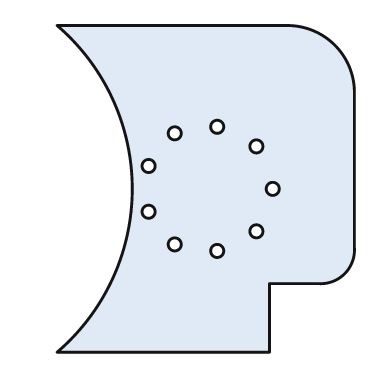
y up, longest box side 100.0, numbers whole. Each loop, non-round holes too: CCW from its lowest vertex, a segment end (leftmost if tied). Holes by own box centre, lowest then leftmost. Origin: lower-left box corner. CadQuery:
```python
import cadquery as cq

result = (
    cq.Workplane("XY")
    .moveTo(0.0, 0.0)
    .lineTo(65.0, 0.0)
    .lineTo(65.0, 21.0)
    .lineTo(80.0, 21.0)
    .threePointArc((88.0, 24.0), (91.0, 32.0))
    .lineTo(91.0, 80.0)
    .threePointArc((85.0, 94.0), (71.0, 100.0))
    .lineTo(0.0, 100.0)
    .threePointArc((23.0, 50.0), (0.0, 0.0))
    .close()
    .moveTo(49.0, 31.0)
    .circle(2.0)
    .moveTo(36.0, 33.0)
    .circle(2.0)
    .moveTo(61.0, 37.0)
    .circle(2.0)
    .moveTo(28.0, 43.0)
    .circle(2.0)
    .moveTo(66.0, 50.0)
    .circle(2.0)
    .moveTo(28.0, 57.0)
    .circle(2.0)
    .moveTo(61.0, 63.0)
    .circle(2.0)
    .moveTo(36.0, 67.0)
    .circle(2.0)
    .moveTo(49.0, 69.0)
    .circle(2.0)
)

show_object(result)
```